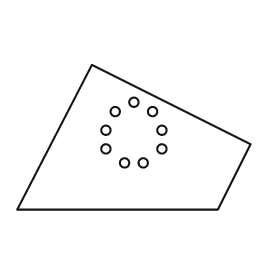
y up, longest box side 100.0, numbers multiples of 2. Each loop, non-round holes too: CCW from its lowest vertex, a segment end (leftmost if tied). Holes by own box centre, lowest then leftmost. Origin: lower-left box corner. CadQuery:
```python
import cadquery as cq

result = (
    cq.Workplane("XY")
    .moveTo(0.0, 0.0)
    .lineTo(86.0, 0.0)
    .lineTo(100.0, 28.0)
    .lineTo(32.0, 62.0)
    .close()
    .moveTo(46.0, 20.0)
    .circle(2.0)
    .moveTo(54.0, 20.0)
    .circle(2.0)
    .moveTo(38.0, 26.0)
    .circle(2.0)
    .moveTo(62.0, 26.0)
    .circle(2.0)
    .moveTo(38.0, 34.0)
    .circle(2.0)
    .moveTo(62.0, 34.0)
    .circle(2.0)
    .moveTo(42.0, 42.0)
    .circle(2.0)
    .moveTo(58.0, 42.0)
    .circle(2.0)
    .moveTo(50.0, 46.0)
    .circle(2.0)
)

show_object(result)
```